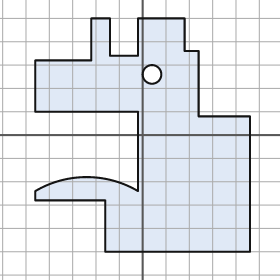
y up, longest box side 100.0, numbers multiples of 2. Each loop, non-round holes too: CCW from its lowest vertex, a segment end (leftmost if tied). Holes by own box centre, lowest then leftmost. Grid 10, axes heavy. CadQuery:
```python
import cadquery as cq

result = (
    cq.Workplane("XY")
    .moveTo(-16.0, -50.0)
    .lineTo(46.0, -50.0)
    .lineTo(46.0, 8.0)
    .lineTo(24.0, 8.0)
    .lineTo(24.0, 36.0)
    .lineTo(18.0, 36.0)
    .lineTo(18.0, 50.0)
    .lineTo(-2.0, 50.0)
    .lineTo(-2.0, 34.0)
    .lineTo(-14.0, 34.0)
    .lineTo(-14.0, 50.0)
    .lineTo(-22.0, 50.0)
    .lineTo(-22.0, 32.0)
    .lineTo(-46.0, 32.0)
    .lineTo(-46.0, 10.0)
    .lineTo(-2.0, 10.0)
    .lineTo(-2.0, -24.0)
    .threePointArc((-24.0, -18.0), (-46.0, -24.0))
    .lineTo(-46.0, -28.0)
    .lineTo(-16.0, -28.0)
    .close()
    .moveTo(4.0, 26.0)
    .circle(4.0)
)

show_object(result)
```